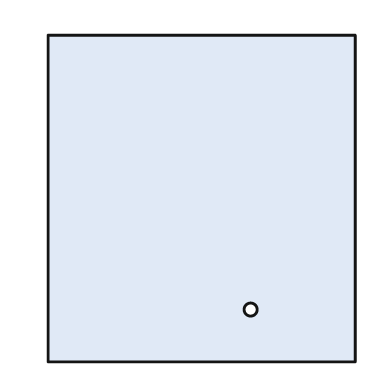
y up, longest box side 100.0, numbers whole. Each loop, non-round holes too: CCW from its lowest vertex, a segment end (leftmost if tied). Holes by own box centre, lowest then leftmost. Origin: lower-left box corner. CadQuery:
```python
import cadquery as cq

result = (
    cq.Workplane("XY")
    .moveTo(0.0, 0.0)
    .lineTo(94.0, 0.0)
    .lineTo(94.0, 100.0)
    .lineTo(0.0, 100.0)
    .close()
    .moveTo(62.0, 16.0)
    .circle(2.0)
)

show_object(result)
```